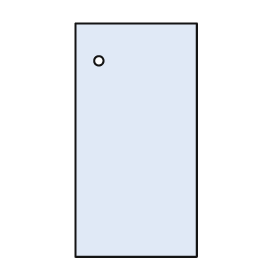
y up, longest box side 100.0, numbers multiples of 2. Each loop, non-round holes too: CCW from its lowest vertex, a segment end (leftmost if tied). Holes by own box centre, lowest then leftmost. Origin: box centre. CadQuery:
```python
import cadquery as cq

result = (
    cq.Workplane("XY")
    .moveTo(-26.0, -50.0)
    .lineTo(26.0, -50.0)
    .lineTo(26.0, 50.0)
    .lineTo(-26.0, 50.0)
    .close()
    .moveTo(-16.0, 34.0)
    .circle(2.0)
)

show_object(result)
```